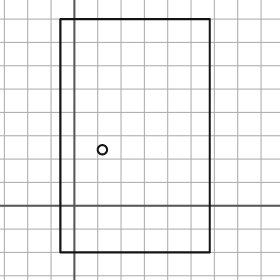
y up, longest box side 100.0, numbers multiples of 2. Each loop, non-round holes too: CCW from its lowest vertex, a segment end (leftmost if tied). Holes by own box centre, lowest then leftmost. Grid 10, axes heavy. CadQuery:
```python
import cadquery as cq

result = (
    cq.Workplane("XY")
    .moveTo(-6.0, -20.0)
    .lineTo(58.0, -20.0)
    .lineTo(58.0, 80.0)
    .lineTo(-6.0, 80.0)
    .close()
    .moveTo(12.0, 24.0)
    .circle(2.0)
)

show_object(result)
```